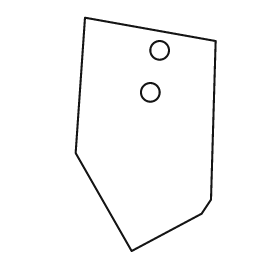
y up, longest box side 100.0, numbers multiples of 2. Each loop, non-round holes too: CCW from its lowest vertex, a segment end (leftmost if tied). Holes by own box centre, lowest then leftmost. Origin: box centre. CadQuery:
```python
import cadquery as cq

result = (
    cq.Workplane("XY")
    .moveTo(-6.0, -50.0)
    .lineTo(24.0, -34.0)
    .lineTo(28.0, -28.0)
    .lineTo(30.0, 40.0)
    .lineTo(-26.0, 50.0)
    .lineTo(-30.0, -8.0)
    .close()
    .moveTo(2.0, 18.0)
    .circle(4.0)
    .moveTo(6.0, 36.0)
    .circle(4.0)
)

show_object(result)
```